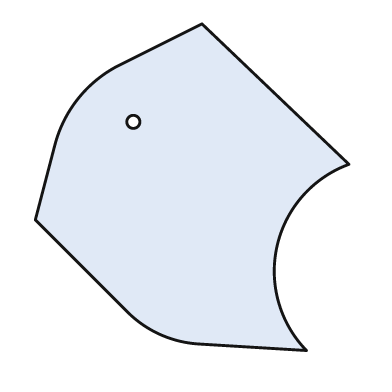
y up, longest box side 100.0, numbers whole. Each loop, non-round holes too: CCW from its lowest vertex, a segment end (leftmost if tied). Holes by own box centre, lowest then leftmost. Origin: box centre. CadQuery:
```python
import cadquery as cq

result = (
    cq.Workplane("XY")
    .moveTo(35.0, -50.0)
    .threePointArc((26.0, -18.0), (48.0, 7.0))
    .lineTo(3.0, 50.0)
    .lineTo(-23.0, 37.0)
    .threePointArc((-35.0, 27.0), (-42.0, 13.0))
    .lineTo(-48.0, -10.0)
    .lineTo(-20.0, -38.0)
    .threePointArc((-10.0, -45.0), (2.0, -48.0))
    .close()
    .moveTo(-18.0, 20.0)
    .circle(2.0)
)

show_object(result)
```